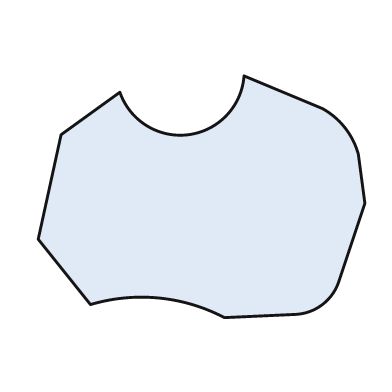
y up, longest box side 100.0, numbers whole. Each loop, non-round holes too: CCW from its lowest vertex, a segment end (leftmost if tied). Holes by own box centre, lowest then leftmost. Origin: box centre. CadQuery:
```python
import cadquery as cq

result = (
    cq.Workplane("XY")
    .moveTo(7.0, -37.0)
    .lineTo(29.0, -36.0)
    .threePointArc((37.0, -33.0), (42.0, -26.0))
    .lineTo(50.0, -2.0)
    .lineTo(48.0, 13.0)
    .threePointArc((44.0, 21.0), (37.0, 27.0))
    .lineTo(13.0, 37.0)
    .threePointArc((-4.0, 19.0), (-25.0, 32.0))
    .lineTo(-43.0, 19.0)
    .lineTo(-50.0, -13.0)
    .lineTo(-34.0, -33.0)
    .threePointArc((-13.0, -31.0), (7.0, -37.0))
    .close()
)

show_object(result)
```